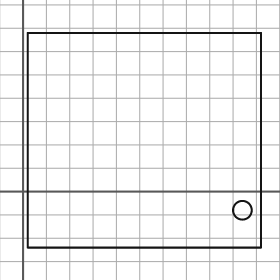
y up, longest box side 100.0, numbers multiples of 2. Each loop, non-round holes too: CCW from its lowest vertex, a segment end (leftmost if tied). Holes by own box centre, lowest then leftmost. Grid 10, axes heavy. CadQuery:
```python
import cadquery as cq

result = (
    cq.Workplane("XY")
    .moveTo(2.0, -24.0)
    .lineTo(102.0, -24.0)
    .lineTo(102.0, 68.0)
    .lineTo(2.0, 68.0)
    .close()
    .moveTo(94.0, -8.0)
    .circle(4.0)
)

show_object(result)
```